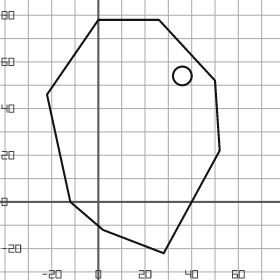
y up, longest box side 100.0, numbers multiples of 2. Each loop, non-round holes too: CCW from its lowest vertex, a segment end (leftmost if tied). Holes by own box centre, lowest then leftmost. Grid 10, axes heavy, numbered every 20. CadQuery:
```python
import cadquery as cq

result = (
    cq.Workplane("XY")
    .moveTo(28.0, -22.0)
    .lineTo(52.0, 22.0)
    .lineTo(50.0, 52.0)
    .lineTo(26.0, 78.0)
    .lineTo(0.0, 78.0)
    .lineTo(-22.0, 46.0)
    .lineTo(-12.0, 0.0)
    .lineTo(2.0, -12.0)
    .close()
    .moveTo(36.0, 54.0)
    .circle(4.0)
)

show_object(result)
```